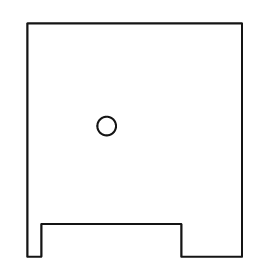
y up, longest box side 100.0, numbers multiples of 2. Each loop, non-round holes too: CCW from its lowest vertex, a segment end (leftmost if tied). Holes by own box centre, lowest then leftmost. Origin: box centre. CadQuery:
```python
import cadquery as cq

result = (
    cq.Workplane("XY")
    .moveTo(-46.0, -50.0)
    .lineTo(-40.0, -50.0)
    .lineTo(-40.0, -36.0)
    .lineTo(20.0, -36.0)
    .lineTo(20.0, -50.0)
    .lineTo(46.0, -50.0)
    .lineTo(46.0, 50.0)
    .lineTo(-46.0, 50.0)
    .close()
    .moveTo(-12.0, 6.0)
    .circle(4.0)
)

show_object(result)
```